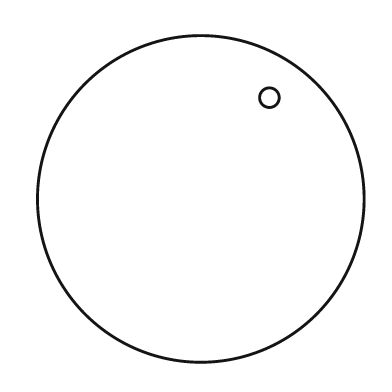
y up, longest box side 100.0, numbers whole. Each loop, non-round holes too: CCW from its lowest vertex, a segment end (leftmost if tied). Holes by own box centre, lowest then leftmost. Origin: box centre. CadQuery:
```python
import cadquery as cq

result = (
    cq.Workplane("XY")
    .moveTo(0.0, 0.0)
    .circle(50.0)
    .moveTo(21.0, 31.0)
    .circle(3.0)
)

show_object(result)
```